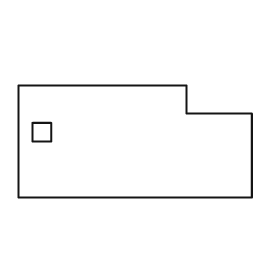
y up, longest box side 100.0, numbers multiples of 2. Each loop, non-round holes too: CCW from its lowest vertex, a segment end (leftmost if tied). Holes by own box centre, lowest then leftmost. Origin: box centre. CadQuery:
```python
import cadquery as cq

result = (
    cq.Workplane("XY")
    .moveTo(-50.0, -24.0)
    .lineTo(50.0, -24.0)
    .lineTo(50.0, 12.0)
    .lineTo(22.0, 12.0)
    .lineTo(22.0, 24.0)
    .lineTo(-50.0, 24.0)
    .close()
    .moveTo(-44.0, 0.0)
    .lineTo(-36.0, 0.0)
    .lineTo(-36.0, 8.0)
    .lineTo(-44.0, 8.0)
    .close()
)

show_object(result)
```